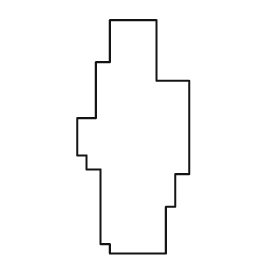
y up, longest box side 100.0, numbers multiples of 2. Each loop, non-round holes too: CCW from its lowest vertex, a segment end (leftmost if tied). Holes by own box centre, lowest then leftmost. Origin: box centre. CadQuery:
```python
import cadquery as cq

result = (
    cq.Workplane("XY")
    .moveTo(-10.0, -50.0)
    .lineTo(14.0, -50.0)
    .lineTo(14.0, -30.0)
    .lineTo(18.0, -30.0)
    .lineTo(18.0, -16.0)
    .lineTo(24.0, -16.0)
    .lineTo(24.0, 24.0)
    .lineTo(10.0, 24.0)
    .lineTo(10.0, 50.0)
    .lineTo(-10.0, 50.0)
    .lineTo(-10.0, 32.0)
    .lineTo(-16.0, 32.0)
    .lineTo(-16.0, 8.0)
    .lineTo(-24.0, 8.0)
    .lineTo(-24.0, -8.0)
    .lineTo(-20.0, -8.0)
    .lineTo(-20.0, -14.0)
    .lineTo(-14.0, -14.0)
    .lineTo(-14.0, -46.0)
    .lineTo(-10.0, -46.0)
    .close()
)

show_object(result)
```